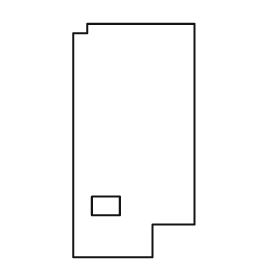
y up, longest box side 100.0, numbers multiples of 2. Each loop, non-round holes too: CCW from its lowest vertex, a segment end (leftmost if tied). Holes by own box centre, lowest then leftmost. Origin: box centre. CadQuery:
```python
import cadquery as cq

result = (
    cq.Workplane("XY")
    .moveTo(-26.0, -50.0)
    .lineTo(8.0, -50.0)
    .lineTo(8.0, -36.0)
    .lineTo(26.0, -36.0)
    .lineTo(26.0, 50.0)
    .lineTo(-20.0, 50.0)
    .lineTo(-20.0, 46.0)
    .lineTo(-26.0, 46.0)
    .close()
    .moveTo(-18.0, -32.0)
    .lineTo(-6.0, -32.0)
    .lineTo(-6.0, -24.0)
    .lineTo(-18.0, -24.0)
    .close()
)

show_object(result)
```